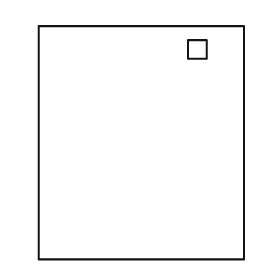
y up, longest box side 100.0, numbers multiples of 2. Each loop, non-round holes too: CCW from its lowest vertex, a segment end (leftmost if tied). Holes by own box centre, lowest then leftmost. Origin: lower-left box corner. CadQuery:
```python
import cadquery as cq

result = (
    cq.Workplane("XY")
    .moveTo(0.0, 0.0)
    .lineTo(88.0, 0.0)
    .lineTo(88.0, 100.0)
    .lineTo(0.0, 100.0)
    .close()
    .moveTo(64.0, 86.0)
    .lineTo(72.0, 86.0)
    .lineTo(72.0, 94.0)
    .lineTo(64.0, 94.0)
    .close()
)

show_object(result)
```